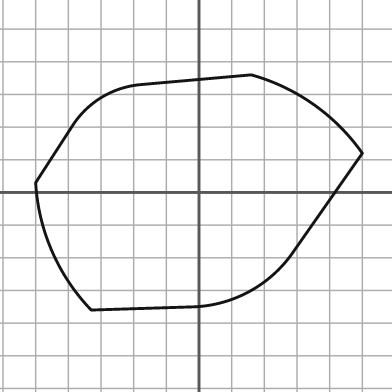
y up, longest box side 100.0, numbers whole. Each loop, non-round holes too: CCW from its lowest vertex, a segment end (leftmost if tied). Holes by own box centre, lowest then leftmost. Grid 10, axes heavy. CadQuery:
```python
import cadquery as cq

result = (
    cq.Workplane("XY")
    .moveTo(-33.0, -36.0)
    .lineTo(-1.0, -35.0)
    .threePointArc((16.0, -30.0), (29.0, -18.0))
    .lineTo(50.0, 12.0)
    .threePointArc((35.0, 27.0), (16.0, 36.0))
    .lineTo(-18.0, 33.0)
    .threePointArc((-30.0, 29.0), (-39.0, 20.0))
    .lineTo(-50.0, 3.0)
    .threePointArc((-45.0, -18.0), (-33.0, -36.0))
    .close()
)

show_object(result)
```